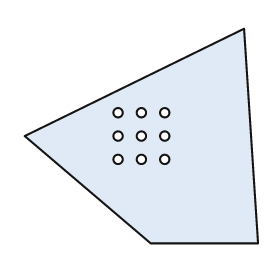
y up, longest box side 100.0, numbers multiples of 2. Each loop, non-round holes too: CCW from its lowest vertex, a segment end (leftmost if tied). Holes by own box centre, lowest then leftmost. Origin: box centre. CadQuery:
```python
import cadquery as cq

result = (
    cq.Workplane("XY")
    .moveTo(4.0, -46.0)
    .lineTo(50.0, -46.0)
    .lineTo(44.0, 46.0)
    .lineTo(-50.0, 0.0)
    .close()
    .moveTo(-10.0, -10.0)
    .circle(2.0)
    .moveTo(0.0, -10.0)
    .circle(2.0)
    .moveTo(10.0, -10.0)
    .circle(2.0)
    .moveTo(-10.0, 0.0)
    .circle(2.0)
    .moveTo(0.0, 0.0)
    .circle(2.0)
    .moveTo(10.0, 0.0)
    .circle(2.0)
    .moveTo(-10.0, 10.0)
    .circle(2.0)
    .moveTo(0.0, 10.0)
    .circle(2.0)
    .moveTo(10.0, 10.0)
    .circle(2.0)
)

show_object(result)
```